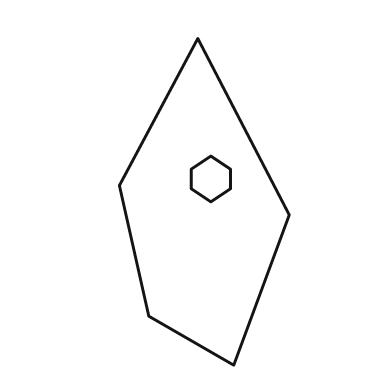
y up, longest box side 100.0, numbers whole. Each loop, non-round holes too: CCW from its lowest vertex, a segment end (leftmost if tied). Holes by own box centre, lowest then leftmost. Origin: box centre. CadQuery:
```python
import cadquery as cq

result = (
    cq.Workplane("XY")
    .moveTo(9.0, -50.0)
    .lineTo(26.0, -4.0)
    .lineTo(-2.0, 50.0)
    .lineTo(-26.0, 5.0)
    .lineTo(-17.0, -35.0)
    .close()
    .moveTo(2.0, 0.0)
    .lineTo(8.0, 4.0)
    .lineTo(8.0, 10.0)
    .lineTo(2.0, 14.0)
    .lineTo(-4.0, 10.0)
    .lineTo(-4.0, 4.0)
    .close()
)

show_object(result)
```